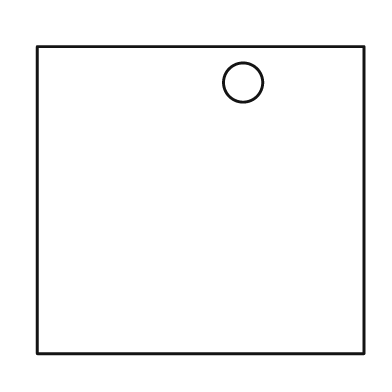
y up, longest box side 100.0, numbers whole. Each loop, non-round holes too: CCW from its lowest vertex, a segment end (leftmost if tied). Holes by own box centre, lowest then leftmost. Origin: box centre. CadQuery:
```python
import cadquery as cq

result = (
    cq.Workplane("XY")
    .moveTo(-50.0, -47.0)
    .lineTo(50.0, -47.0)
    .lineTo(50.0, 47.0)
    .lineTo(-50.0, 47.0)
    .close()
    .moveTo(13.0, 36.0)
    .circle(6.0)
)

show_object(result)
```